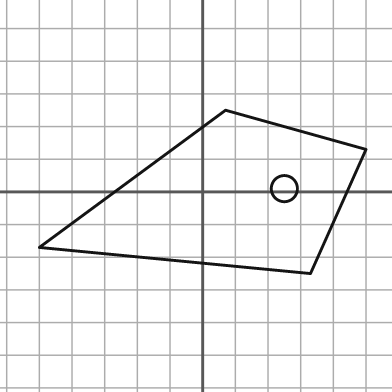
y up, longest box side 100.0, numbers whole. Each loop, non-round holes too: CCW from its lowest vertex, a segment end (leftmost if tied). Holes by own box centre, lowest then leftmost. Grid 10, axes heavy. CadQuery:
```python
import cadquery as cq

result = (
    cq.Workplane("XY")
    .moveTo(33.0, -25.0)
    .lineTo(50.0, 13.0)
    .lineTo(7.0, 25.0)
    .lineTo(-50.0, -17.0)
    .close()
    .moveTo(25.0, 1.0)
    .circle(4.0)
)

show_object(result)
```